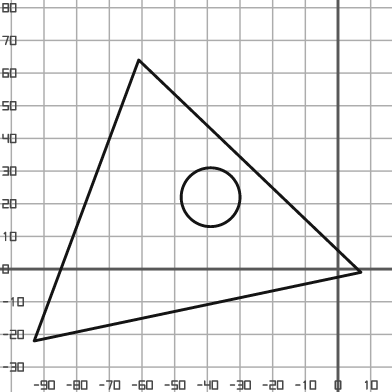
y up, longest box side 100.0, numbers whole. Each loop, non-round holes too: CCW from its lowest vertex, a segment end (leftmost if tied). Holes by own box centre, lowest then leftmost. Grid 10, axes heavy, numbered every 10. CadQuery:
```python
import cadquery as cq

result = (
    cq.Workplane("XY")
    .moveTo(-93.0, -22.0)
    .lineTo(7.0, -1.0)
    .lineTo(-61.0, 64.0)
    .close()
    .moveTo(-39.0, 22.0)
    .circle(9.0)
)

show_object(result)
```